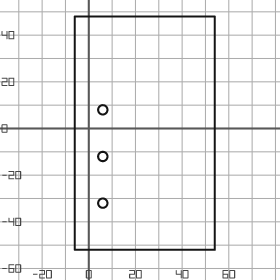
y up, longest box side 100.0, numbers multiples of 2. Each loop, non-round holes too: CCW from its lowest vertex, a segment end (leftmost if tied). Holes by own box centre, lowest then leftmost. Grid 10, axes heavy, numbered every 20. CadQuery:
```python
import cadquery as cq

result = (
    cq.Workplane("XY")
    .moveTo(-6.0, -52.0)
    .lineTo(54.0, -52.0)
    .lineTo(54.0, 48.0)
    .lineTo(-6.0, 48.0)
    .close()
    .moveTo(6.0, -32.0)
    .circle(2.0)
    .moveTo(6.0, -12.0)
    .circle(2.0)
    .moveTo(6.0, 8.0)
    .circle(2.0)
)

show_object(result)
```